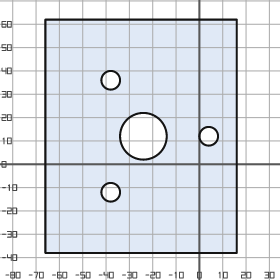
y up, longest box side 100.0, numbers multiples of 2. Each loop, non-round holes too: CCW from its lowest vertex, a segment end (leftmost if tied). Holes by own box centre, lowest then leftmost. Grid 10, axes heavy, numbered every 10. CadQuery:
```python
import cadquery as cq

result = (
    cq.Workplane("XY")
    .moveTo(-66.0, -38.0)
    .lineTo(16.0, -38.0)
    .lineTo(16.0, 62.0)
    .lineTo(-66.0, 62.0)
    .close()
    .moveTo(-38.0, -12.0)
    .circle(4.0)
    .moveTo(-24.0, 12.0)
    .circle(10.0)
    .moveTo(4.0, 12.0)
    .circle(4.0)
    .moveTo(-38.0, 36.0)
    .circle(4.0)
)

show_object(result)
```